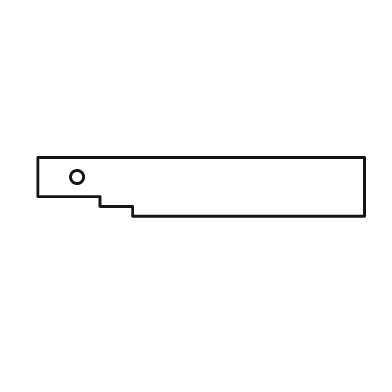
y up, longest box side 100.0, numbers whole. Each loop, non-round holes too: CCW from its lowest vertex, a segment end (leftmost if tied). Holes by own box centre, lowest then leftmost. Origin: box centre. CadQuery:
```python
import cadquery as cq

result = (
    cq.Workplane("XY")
    .moveTo(-21.0, -9.0)
    .lineTo(50.0, -9.0)
    .lineTo(50.0, 9.0)
    .lineTo(-50.0, 9.0)
    .lineTo(-50.0, -3.0)
    .lineTo(-31.0, -3.0)
    .lineTo(-31.0, -6.0)
    .lineTo(-21.0, -6.0)
    .close()
    .moveTo(-38.0, 3.0)
    .circle(2.0)
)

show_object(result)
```